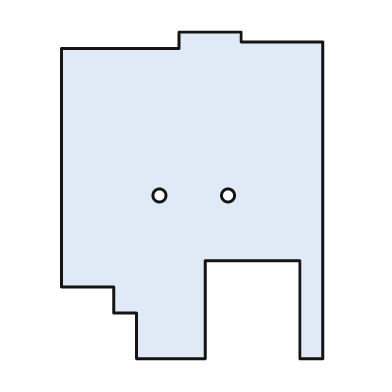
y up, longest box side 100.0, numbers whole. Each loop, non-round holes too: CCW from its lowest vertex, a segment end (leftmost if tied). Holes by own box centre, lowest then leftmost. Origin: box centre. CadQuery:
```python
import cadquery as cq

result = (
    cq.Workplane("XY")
    .moveTo(-17.0, -50.0)
    .lineTo(4.0, -50.0)
    .lineTo(4.0, -20.0)
    .lineTo(33.0, -20.0)
    .lineTo(33.0, -50.0)
    .lineTo(40.0, -50.0)
    .lineTo(40.0, 47.0)
    .lineTo(15.0, 47.0)
    .lineTo(15.0, 50.0)
    .lineTo(-4.0, 50.0)
    .lineTo(-4.0, 45.0)
    .lineTo(-40.0, 45.0)
    .lineTo(-40.0, -28.0)
    .lineTo(-24.0, -28.0)
    .lineTo(-24.0, -36.0)
    .lineTo(-17.0, -36.0)
    .close()
    .moveTo(-10.0, 0.0)
    .circle(2.0)
    .moveTo(11.0, 0.0)
    .circle(2.0)
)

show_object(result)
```